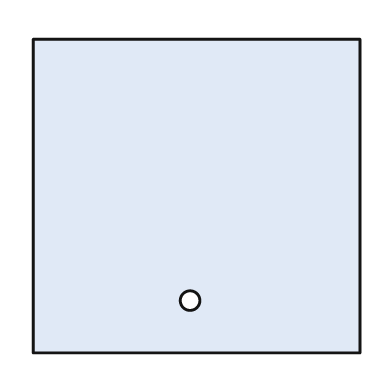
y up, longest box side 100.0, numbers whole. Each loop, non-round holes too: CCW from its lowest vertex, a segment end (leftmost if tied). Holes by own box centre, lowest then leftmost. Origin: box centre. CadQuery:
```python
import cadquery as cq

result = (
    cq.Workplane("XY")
    .moveTo(-50.0, -48.0)
    .lineTo(50.0, -48.0)
    .lineTo(50.0, 48.0)
    .lineTo(-50.0, 48.0)
    .close()
    .moveTo(-2.0, -32.0)
    .circle(3.0)
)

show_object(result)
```